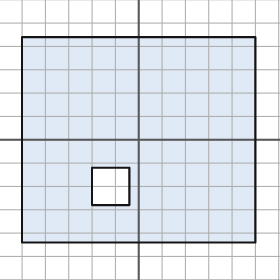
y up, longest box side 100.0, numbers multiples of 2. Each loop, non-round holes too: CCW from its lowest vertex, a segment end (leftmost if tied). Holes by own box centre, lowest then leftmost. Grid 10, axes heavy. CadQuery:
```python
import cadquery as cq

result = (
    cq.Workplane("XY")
    .moveTo(-50.0, -44.0)
    .lineTo(50.0, -44.0)
    .lineTo(50.0, 44.0)
    .lineTo(-50.0, 44.0)
    .close()
    .moveTo(-20.0, -28.0)
    .lineTo(-4.0, -28.0)
    .lineTo(-4.0, -12.0)
    .lineTo(-20.0, -12.0)
    .close()
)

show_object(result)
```